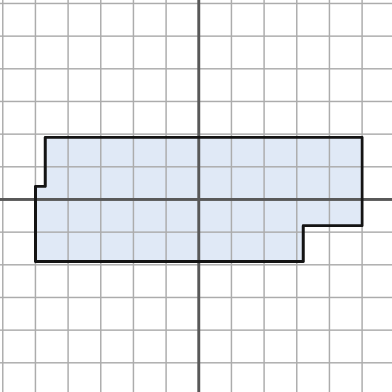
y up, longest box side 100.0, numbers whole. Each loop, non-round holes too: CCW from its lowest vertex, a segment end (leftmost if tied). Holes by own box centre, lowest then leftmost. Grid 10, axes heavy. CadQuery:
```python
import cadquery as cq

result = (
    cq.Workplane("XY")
    .moveTo(-50.0, -19.0)
    .lineTo(32.0, -19.0)
    .lineTo(32.0, -8.0)
    .lineTo(50.0, -8.0)
    .lineTo(50.0, 19.0)
    .lineTo(-47.0, 19.0)
    .lineTo(-47.0, 4.0)
    .lineTo(-50.0, 4.0)
    .close()
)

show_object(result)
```